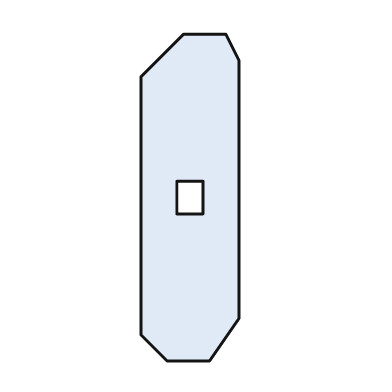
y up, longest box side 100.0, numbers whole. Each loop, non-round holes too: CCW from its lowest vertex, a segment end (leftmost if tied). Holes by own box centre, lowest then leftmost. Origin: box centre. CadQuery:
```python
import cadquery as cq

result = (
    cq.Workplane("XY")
    .moveTo(-7.0, -50.0)
    .lineTo(6.0, -50.0)
    .lineTo(15.0, -37.0)
    .lineTo(15.0, 42.0)
    .lineTo(11.0, 50.0)
    .lineTo(-2.0, 50.0)
    .lineTo(-15.0, 37.0)
    .lineTo(-15.0, -42.0)
    .close()
    .moveTo(-4.0, -5.0)
    .lineTo(4.0, -5.0)
    .lineTo(4.0, 5.0)
    .lineTo(-4.0, 5.0)
    .close()
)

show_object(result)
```